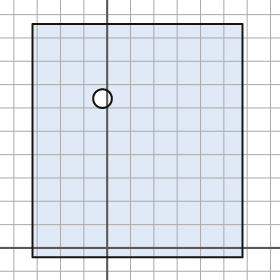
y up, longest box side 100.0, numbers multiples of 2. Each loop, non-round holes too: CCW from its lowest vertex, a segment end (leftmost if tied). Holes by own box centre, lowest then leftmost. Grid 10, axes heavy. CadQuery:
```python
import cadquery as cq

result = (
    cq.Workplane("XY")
    .moveTo(-32.0, -4.0)
    .lineTo(58.0, -4.0)
    .lineTo(58.0, 96.0)
    .lineTo(-32.0, 96.0)
    .close()
    .moveTo(-2.0, 64.0)
    .circle(4.0)
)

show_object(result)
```